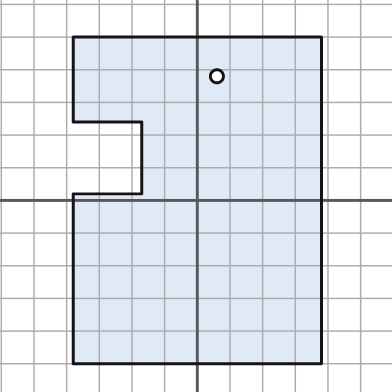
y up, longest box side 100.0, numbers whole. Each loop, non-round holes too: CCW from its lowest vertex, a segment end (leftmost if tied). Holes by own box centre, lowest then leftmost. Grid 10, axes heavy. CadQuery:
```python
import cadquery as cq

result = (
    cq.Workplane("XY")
    .moveTo(-38.0, -50.0)
    .lineTo(38.0, -50.0)
    .lineTo(38.0, 50.0)
    .lineTo(-38.0, 50.0)
    .lineTo(-38.0, 24.0)
    .lineTo(-17.0, 24.0)
    .lineTo(-17.0, 2.0)
    .lineTo(-38.0, 2.0)
    .close()
    .moveTo(6.0, 38.0)
    .circle(2.0)
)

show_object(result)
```